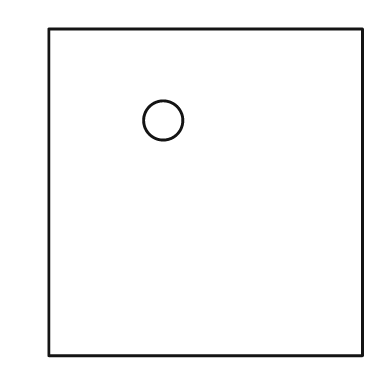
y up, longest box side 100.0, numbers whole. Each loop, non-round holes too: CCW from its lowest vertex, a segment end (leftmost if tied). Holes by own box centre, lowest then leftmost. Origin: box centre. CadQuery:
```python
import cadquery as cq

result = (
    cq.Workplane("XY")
    .moveTo(-48.0, -50.0)
    .lineTo(48.0, -50.0)
    .lineTo(48.0, 50.0)
    .lineTo(-48.0, 50.0)
    .close()
    .moveTo(-13.0, 22.0)
    .circle(6.0)
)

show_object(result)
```